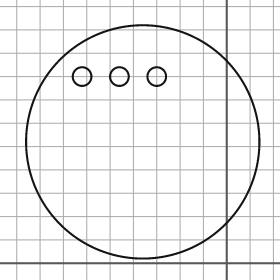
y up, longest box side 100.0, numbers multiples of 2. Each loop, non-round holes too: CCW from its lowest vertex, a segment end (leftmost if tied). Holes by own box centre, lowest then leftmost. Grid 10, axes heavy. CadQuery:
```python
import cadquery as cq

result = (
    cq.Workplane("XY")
    .moveTo(-36.0, 52.0)
    .circle(50.0)
    .moveTo(-62.0, 80.0)
    .circle(4.0)
    .moveTo(-46.0, 80.0)
    .circle(4.0)
    .moveTo(-30.0, 80.0)
    .circle(4.0)
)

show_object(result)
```